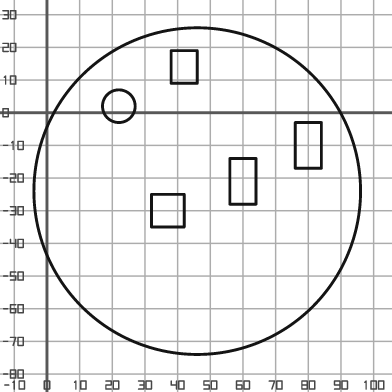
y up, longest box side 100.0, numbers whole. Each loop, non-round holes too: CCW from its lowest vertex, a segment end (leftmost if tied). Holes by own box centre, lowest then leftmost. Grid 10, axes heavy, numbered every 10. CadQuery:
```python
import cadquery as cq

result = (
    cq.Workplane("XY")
    .moveTo(46.0, -24.0)
    .circle(50.0)
    .moveTo(32.0, -35.0)
    .lineTo(42.0, -35.0)
    .lineTo(42.0, -25.0)
    .lineTo(32.0, -25.0)
    .close()
    .moveTo(56.0, -28.0)
    .lineTo(64.0, -28.0)
    .lineTo(64.0, -14.0)
    .lineTo(56.0, -14.0)
    .close()
    .moveTo(76.0, -17.0)
    .lineTo(84.0, -17.0)
    .lineTo(84.0, -3.0)
    .lineTo(76.0, -3.0)
    .close()
    .moveTo(22.0, 2.0)
    .circle(5.0)
    .moveTo(38.0, 9.0)
    .lineTo(46.0, 9.0)
    .lineTo(46.0, 19.0)
    .lineTo(38.0, 19.0)
    .close()
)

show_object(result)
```